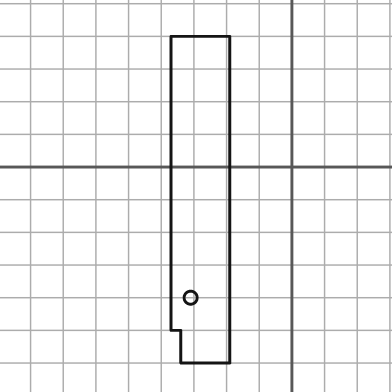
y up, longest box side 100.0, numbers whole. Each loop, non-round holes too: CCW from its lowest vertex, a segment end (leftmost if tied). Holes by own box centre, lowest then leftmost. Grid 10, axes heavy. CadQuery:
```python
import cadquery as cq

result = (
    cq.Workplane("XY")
    .moveTo(-34.0, -60.0)
    .lineTo(-19.0, -60.0)
    .lineTo(-19.0, 40.0)
    .lineTo(-37.0, 40.0)
    .lineTo(-37.0, -50.0)
    .lineTo(-34.0, -50.0)
    .close()
    .moveTo(-31.0, -40.0)
    .circle(2.0)
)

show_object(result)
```